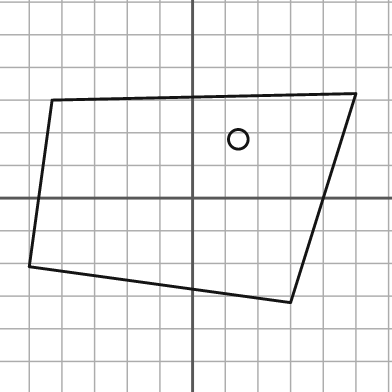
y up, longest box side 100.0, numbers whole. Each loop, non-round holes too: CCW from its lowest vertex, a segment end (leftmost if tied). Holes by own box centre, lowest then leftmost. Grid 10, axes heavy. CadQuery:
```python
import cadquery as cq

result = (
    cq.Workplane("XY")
    .moveTo(30.0, -32.0)
    .lineTo(50.0, 32.0)
    .lineTo(-43.0, 30.0)
    .lineTo(-50.0, -21.0)
    .close()
    .moveTo(14.0, 18.0)
    .circle(3.0)
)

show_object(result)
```